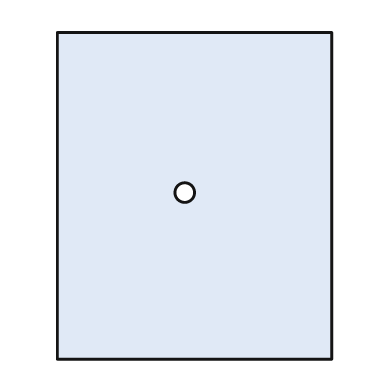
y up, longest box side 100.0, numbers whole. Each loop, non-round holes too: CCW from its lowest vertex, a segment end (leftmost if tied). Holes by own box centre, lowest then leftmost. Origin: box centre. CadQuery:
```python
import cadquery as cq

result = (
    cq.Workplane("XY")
    .moveTo(-42.0, -50.0)
    .lineTo(42.0, -50.0)
    .lineTo(42.0, 50.0)
    .lineTo(-42.0, 50.0)
    .close()
    .moveTo(-3.0, 1.0)
    .circle(3.0)
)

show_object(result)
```